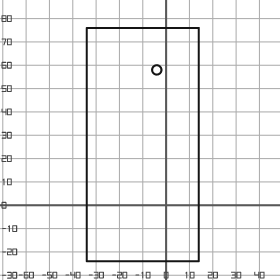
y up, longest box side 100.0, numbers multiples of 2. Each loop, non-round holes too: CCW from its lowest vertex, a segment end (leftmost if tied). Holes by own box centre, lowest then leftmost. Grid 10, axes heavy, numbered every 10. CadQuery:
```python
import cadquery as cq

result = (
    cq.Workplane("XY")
    .moveTo(-34.0, -24.0)
    .lineTo(14.0, -24.0)
    .lineTo(14.0, 76.0)
    .lineTo(-34.0, 76.0)
    .close()
    .moveTo(-4.0, 58.0)
    .circle(2.0)
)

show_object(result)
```